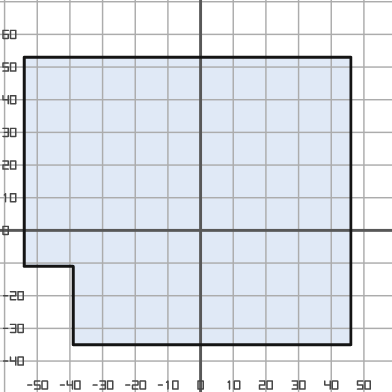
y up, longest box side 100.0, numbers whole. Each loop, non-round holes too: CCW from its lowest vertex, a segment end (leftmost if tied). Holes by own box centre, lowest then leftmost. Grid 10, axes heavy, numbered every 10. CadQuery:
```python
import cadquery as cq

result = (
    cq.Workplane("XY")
    .moveTo(-39.0, -35.0)
    .lineTo(46.0, -35.0)
    .lineTo(46.0, 53.0)
    .lineTo(-54.0, 53.0)
    .lineTo(-54.0, -11.0)
    .lineTo(-39.0, -11.0)
    .close()
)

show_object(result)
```